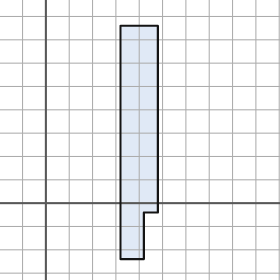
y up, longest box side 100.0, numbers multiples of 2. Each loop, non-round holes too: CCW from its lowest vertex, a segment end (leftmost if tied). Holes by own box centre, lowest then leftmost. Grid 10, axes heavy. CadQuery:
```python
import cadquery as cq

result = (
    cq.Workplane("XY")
    .moveTo(32.0, -24.0)
    .lineTo(42.0, -24.0)
    .lineTo(42.0, -4.0)
    .lineTo(48.0, -4.0)
    .lineTo(48.0, 76.0)
    .lineTo(32.0, 76.0)
    .close()
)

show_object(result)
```